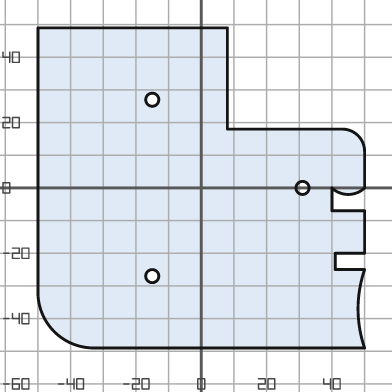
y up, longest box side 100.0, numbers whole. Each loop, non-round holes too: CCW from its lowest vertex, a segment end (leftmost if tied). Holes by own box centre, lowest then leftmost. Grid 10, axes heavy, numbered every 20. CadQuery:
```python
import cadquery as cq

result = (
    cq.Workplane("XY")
    .moveTo(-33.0, -49.0)
    .lineTo(50.0, -49.0)
    .threePointArc((48.0, -37.0), (50.0, -25.0))
    .lineTo(41.0, -25.0)
    .lineTo(41.0, -20.0)
    .lineTo(50.0, -20.0)
    .lineTo(50.0, -7.0)
    .lineTo(40.0, -7.0)
    .lineTo(40.0, 0.0)
    .threePointArc((45.0, -2.0), (50.0, 0.0))
    .lineTo(50.0, 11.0)
    .threePointArc((48.0, 16.0), (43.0, 18.0))
    .lineTo(8.0, 18.0)
    .lineTo(8.0, 49.0)
    .lineTo(-50.0, 49.0)
    .lineTo(-50.0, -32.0)
    .threePointArc((-45.0, -44.0), (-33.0, -49.0))
    .close()
    .moveTo(-15.0, -27.0)
    .circle(2.0)
    .moveTo(31.0, 0.0)
    .circle(2.0)
    .moveTo(-15.0, 27.0)
    .circle(2.0)
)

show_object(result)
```